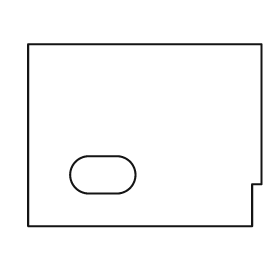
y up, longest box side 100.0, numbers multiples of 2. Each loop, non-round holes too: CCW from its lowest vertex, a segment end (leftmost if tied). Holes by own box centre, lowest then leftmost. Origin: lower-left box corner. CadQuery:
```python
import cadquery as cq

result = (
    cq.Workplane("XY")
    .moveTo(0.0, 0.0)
    .lineTo(96.0, 0.0)
    .lineTo(96.0, 18.0)
    .lineTo(100.0, 18.0)
    .lineTo(100.0, 78.0)
    .lineTo(0.0, 78.0)
    .close()
    .moveTo(26.0, 14.0)
    .lineTo(38.0, 14.0)
    .threePointArc((46.0, 22.0), (38.0, 30.0))
    .lineTo(26.0, 30.0)
    .threePointArc((18.0, 22.0), (26.0, 14.0))
    .close()
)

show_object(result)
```